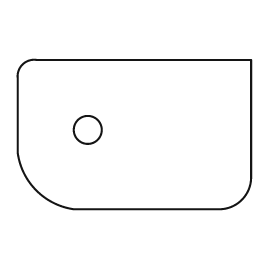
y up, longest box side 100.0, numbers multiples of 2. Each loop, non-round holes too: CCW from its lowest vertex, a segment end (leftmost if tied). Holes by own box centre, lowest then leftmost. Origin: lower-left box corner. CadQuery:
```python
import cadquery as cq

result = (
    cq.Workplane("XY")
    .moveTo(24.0, 0.0)
    .lineTo(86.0, 0.0)
    .threePointArc((96.0, 4.0), (100.0, 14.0))
    .lineTo(100.0, 64.0)
    .lineTo(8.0, 64.0)
    .threePointArc((2.0, 62.0), (0.0, 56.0))
    .lineTo(0.0, 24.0)
    .threePointArc((8.0, 8.0), (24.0, 0.0))
    .close()
    .moveTo(30.0, 34.0)
    .circle(6.0)
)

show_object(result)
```